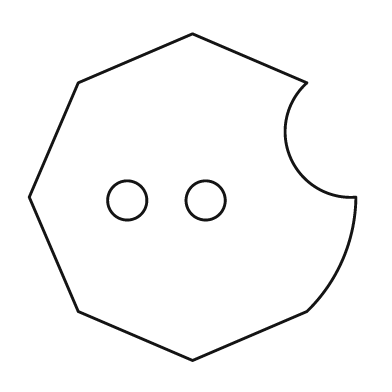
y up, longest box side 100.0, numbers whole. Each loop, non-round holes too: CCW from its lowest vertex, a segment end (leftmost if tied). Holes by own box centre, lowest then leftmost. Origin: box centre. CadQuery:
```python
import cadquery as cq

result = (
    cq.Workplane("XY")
    .moveTo(0.0, -50.0)
    .lineTo(35.0, -35.0)
    .threePointArc((46.0, -19.0), (50.0, 0.0))
    .threePointArc((30.0, 12.0), (35.0, 35.0))
    .lineTo(0.0, 50.0)
    .lineTo(-35.0, 35.0)
    .lineTo(-50.0, 0.0)
    .lineTo(-35.0, -35.0)
    .close()
    .moveTo(-20.0, -1.0)
    .circle(6.0)
    .moveTo(4.0, -1.0)
    .circle(6.0)
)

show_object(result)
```